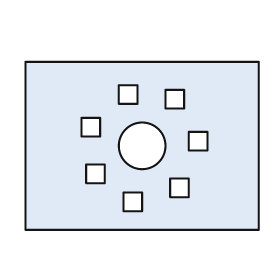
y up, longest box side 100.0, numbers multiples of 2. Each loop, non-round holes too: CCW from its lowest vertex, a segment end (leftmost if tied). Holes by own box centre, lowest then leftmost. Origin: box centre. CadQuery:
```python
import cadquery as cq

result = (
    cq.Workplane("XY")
    .moveTo(-50.0, -36.0)
    .lineTo(50.0, -36.0)
    .lineTo(50.0, 36.0)
    .lineTo(-50.0, 36.0)
    .close()
    .moveTo(-8.0, -28.0)
    .lineTo(0.0, -28.0)
    .lineTo(0.0, -20.0)
    .lineTo(-8.0, -20.0)
    .close()
    .moveTo(12.0, -22.0)
    .lineTo(20.0, -22.0)
    .lineTo(20.0, -14.0)
    .lineTo(12.0, -14.0)
    .close()
    .moveTo(-24.0, -16.0)
    .lineTo(-16.0, -16.0)
    .lineTo(-16.0, -8.0)
    .lineTo(-24.0, -8.0)
    .close()
    .moveTo(0.0, 0.0)
    .circle(10.0)
    .moveTo(20.0, -2.0)
    .lineTo(28.0, -2.0)
    .lineTo(28.0, 6.0)
    .lineTo(20.0, 6.0)
    .close()
    .moveTo(-26.0, 4.0)
    .lineTo(-18.0, 4.0)
    .lineTo(-18.0, 12.0)
    .lineTo(-26.0, 12.0)
    .close()
    .moveTo(10.0, 16.0)
    .lineTo(18.0, 16.0)
    .lineTo(18.0, 24.0)
    .lineTo(10.0, 24.0)
    .close()
    .moveTo(-10.0, 18.0)
    .lineTo(-2.0, 18.0)
    .lineTo(-2.0, 26.0)
    .lineTo(-10.0, 26.0)
    .close()
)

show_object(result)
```